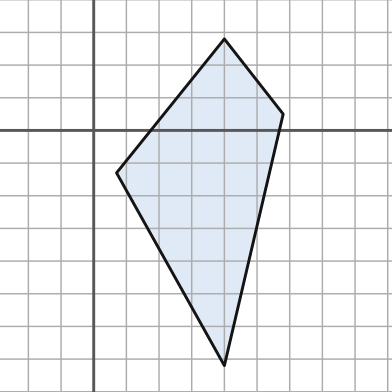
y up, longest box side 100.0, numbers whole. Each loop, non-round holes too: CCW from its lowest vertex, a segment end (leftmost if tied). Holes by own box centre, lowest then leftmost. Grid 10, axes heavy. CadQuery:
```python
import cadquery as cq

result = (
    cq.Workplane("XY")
    .moveTo(40.0, -72.0)
    .lineTo(58.0, 5.0)
    .lineTo(40.0, 28.0)
    .lineTo(7.0, -13.0)
    .close()
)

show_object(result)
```